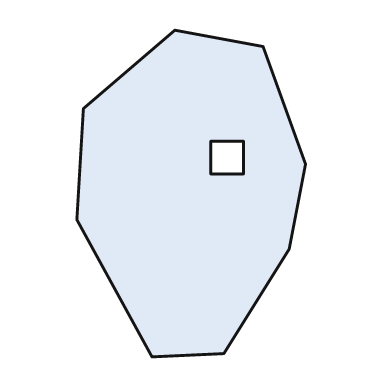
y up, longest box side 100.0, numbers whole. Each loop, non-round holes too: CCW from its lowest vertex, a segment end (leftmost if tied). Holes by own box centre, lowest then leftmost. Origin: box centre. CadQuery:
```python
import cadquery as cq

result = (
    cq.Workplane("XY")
    .moveTo(-12.0, -50.0)
    .lineTo(10.0, -49.0)
    .lineTo(30.0, -17.0)
    .lineTo(35.0, 9.0)
    .lineTo(22.0, 45.0)
    .lineTo(-5.0, 50.0)
    .lineTo(-33.0, 26.0)
    .lineTo(-35.0, -8.0)
    .close()
    .moveTo(6.0, 6.0)
    .lineTo(16.0, 6.0)
    .lineTo(16.0, 16.0)
    .lineTo(6.0, 16.0)
    .close()
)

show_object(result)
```